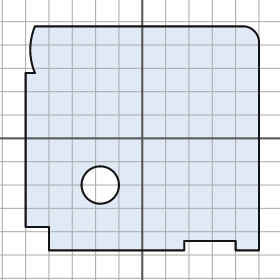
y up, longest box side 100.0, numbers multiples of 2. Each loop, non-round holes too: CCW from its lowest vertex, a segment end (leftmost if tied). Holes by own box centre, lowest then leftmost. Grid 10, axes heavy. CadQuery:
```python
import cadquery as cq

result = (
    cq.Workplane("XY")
    .moveTo(-40.0, -48.0)
    .lineTo(18.0, -48.0)
    .lineTo(18.0, -44.0)
    .lineTo(40.0, -44.0)
    .lineTo(40.0, -48.0)
    .lineTo(50.0, -48.0)
    .lineTo(50.0, 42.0)
    .threePointArc((48.0, 46.0), (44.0, 48.0))
    .lineTo(-46.0, 48.0)
    .threePointArc((-48.0, 38.0), (-46.0, 28.0))
    .lineTo(-50.0, 28.0)
    .lineTo(-50.0, -38.0)
    .lineTo(-40.0, -38.0)
    .close()
    .moveTo(-18.0, -20.0)
    .circle(8.0)
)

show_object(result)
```